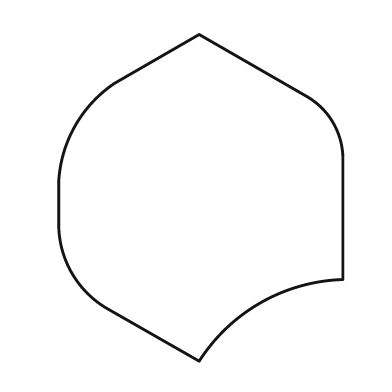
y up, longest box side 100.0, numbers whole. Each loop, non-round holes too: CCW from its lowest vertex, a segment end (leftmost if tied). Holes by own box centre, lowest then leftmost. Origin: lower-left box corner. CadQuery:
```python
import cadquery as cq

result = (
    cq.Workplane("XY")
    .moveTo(43.0, 0.0)
    .threePointArc((62.0, 18.0), (87.0, 25.0))
    .lineTo(87.0, 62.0)
    .threePointArc((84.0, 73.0), (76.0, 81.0))
    .lineTo(43.0, 100.0)
    .lineTo(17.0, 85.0)
    .threePointArc((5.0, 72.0), (0.0, 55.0))
    .lineTo(0.0, 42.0)
    .threePointArc((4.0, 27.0), (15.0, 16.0))
    .close()
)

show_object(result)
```